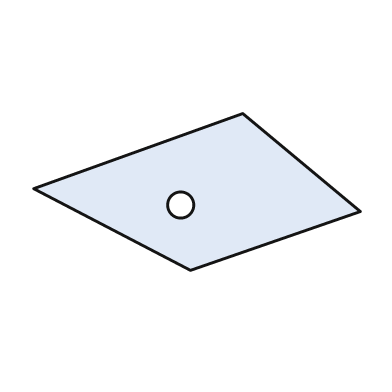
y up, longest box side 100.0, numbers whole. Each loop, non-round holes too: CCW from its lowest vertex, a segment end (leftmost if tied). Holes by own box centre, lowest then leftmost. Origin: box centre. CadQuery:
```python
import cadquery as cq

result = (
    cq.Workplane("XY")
    .moveTo(-2.0, -24.0)
    .lineTo(50.0, -6.0)
    .lineTo(14.0, 24.0)
    .lineTo(-50.0, 1.0)
    .close()
    .moveTo(-5.0, -4.0)
    .circle(4.0)
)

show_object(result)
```